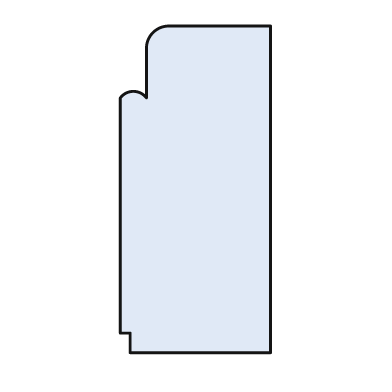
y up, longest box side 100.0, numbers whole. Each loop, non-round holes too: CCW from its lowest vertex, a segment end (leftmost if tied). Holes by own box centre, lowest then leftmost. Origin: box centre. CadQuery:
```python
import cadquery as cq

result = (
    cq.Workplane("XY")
    .moveTo(-20.0, -50.0)
    .lineTo(23.0, -50.0)
    .lineTo(23.0, 50.0)
    .lineTo(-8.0, 50.0)
    .threePointArc((-13.0, 48.0), (-15.0, 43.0))
    .lineTo(-15.0, 28.0)
    .threePointArc((-19.0, 30.0), (-23.0, 28.0))
    .lineTo(-23.0, -44.0)
    .lineTo(-20.0, -44.0)
    .close()
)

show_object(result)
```